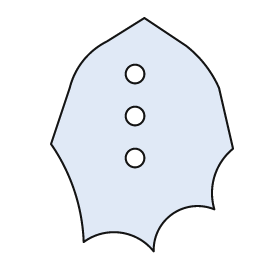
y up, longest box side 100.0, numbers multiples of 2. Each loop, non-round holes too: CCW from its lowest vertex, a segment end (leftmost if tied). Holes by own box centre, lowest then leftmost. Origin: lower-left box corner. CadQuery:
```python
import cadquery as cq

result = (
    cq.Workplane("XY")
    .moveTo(44.0, 0.0)
    .threePointArc((52.0, 16.0), (70.0, 18.0))
    .threePointArc((70.0, 32.0), (78.0, 44.0))
    .lineTo(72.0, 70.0)
    .threePointArc((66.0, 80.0), (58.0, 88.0))
    .lineTo(40.0, 100.0)
    .lineTo(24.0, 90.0)
    .threePointArc((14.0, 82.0), (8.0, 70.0))
    .lineTo(0.0, 46.0)
    .threePointArc((10.0, 26.0), (14.0, 4.0))
    .threePointArc((30.0, 8.0), (44.0, 0.0))
    .close()
    .moveTo(36.0, 40.0)
    .circle(4.0)
    .moveTo(36.0, 58.0)
    .circle(4.0)
    .moveTo(36.0, 76.0)
    .circle(4.0)
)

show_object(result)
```